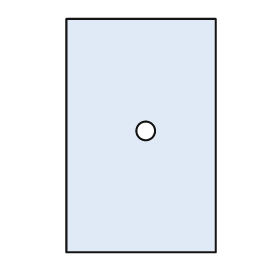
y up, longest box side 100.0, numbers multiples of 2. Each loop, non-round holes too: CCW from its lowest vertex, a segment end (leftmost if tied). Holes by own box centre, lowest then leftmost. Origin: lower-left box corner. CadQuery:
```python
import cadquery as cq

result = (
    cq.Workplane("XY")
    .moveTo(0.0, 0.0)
    .lineTo(64.0, 0.0)
    .lineTo(64.0, 100.0)
    .lineTo(0.0, 100.0)
    .close()
    .moveTo(34.0, 52.0)
    .circle(4.0)
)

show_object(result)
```